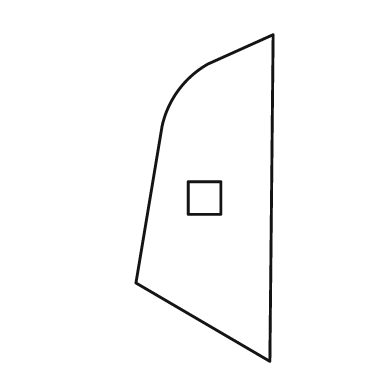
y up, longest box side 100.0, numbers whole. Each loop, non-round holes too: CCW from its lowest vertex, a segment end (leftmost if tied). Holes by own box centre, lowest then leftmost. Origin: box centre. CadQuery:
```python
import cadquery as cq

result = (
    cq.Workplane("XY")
    .moveTo(20.0, -50.0)
    .lineTo(21.0, 50.0)
    .lineTo(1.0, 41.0)
    .threePointArc((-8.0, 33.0), (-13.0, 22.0))
    .lineTo(-21.0, -26.0)
    .close()
    .moveTo(-5.0, -5.0)
    .lineTo(5.0, -5.0)
    .lineTo(5.0, 5.0)
    .lineTo(-5.0, 5.0)
    .close()
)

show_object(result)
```